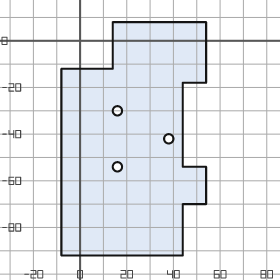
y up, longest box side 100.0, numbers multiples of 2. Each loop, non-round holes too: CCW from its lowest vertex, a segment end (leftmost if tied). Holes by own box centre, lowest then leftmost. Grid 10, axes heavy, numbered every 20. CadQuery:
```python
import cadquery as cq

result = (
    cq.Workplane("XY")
    .moveTo(-8.0, -92.0)
    .lineTo(44.0, -92.0)
    .lineTo(44.0, -70.0)
    .lineTo(54.0, -70.0)
    .lineTo(54.0, -54.0)
    .lineTo(44.0, -54.0)
    .lineTo(44.0, -18.0)
    .lineTo(54.0, -18.0)
    .lineTo(54.0, 8.0)
    .lineTo(14.0, 8.0)
    .lineTo(14.0, -12.0)
    .lineTo(-8.0, -12.0)
    .close()
    .moveTo(16.0, -54.0)
    .circle(2.0)
    .moveTo(38.0, -42.0)
    .circle(2.0)
    .moveTo(16.0, -30.0)
    .circle(2.0)
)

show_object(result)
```